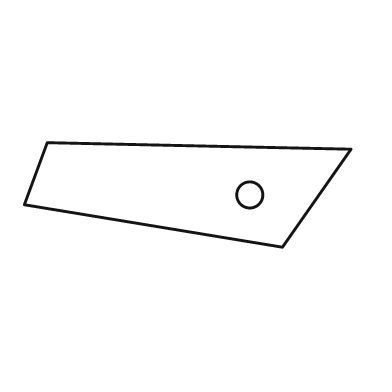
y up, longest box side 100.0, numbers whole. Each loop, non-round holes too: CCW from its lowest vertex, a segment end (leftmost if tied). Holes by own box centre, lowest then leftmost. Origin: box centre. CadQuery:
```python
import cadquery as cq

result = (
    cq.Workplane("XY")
    .moveTo(29.0, -16.0)
    .lineTo(50.0, 14.0)
    .lineTo(-43.0, 16.0)
    .lineTo(-50.0, -3.0)
    .close()
    .moveTo(19.0, 0.0)
    .circle(4.0)
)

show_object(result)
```